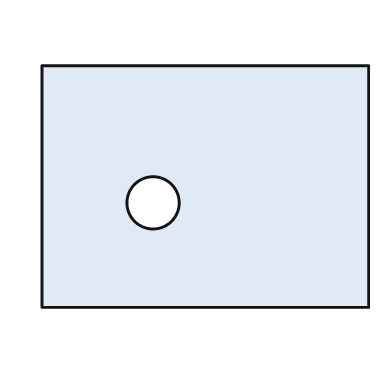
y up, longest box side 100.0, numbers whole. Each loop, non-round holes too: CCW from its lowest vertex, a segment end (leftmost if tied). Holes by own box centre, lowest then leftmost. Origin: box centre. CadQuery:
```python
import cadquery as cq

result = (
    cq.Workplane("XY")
    .moveTo(-50.0, -37.0)
    .lineTo(50.0, -37.0)
    .lineTo(50.0, 37.0)
    .lineTo(-50.0, 37.0)
    .close()
    .moveTo(-16.0, -5.0)
    .circle(8.0)
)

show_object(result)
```